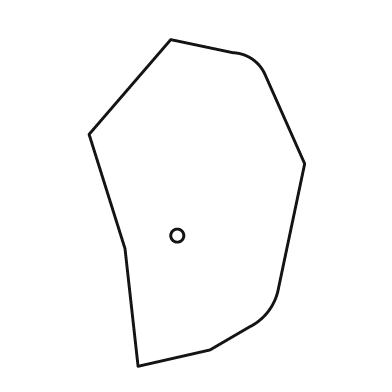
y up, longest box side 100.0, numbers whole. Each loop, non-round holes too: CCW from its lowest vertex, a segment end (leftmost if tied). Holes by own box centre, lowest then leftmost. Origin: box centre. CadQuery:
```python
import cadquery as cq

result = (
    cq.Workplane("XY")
    .moveTo(-18.0, -50.0)
    .lineTo(4.0, -45.0)
    .lineTo(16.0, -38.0)
    .threePointArc((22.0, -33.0), (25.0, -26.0))
    .lineTo(33.0, 12.0)
    .lineTo(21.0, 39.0)
    .threePointArc((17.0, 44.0), (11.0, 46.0))
    .lineTo(-8.0, 50.0)
    .lineTo(-33.0, 21.0)
    .lineTo(-22.0, -14.0)
    .close()
    .moveTo(-6.0, -10.0)
    .circle(2.0)
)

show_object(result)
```